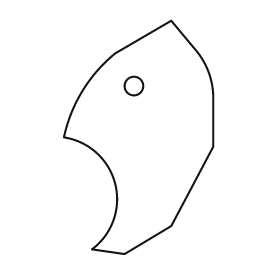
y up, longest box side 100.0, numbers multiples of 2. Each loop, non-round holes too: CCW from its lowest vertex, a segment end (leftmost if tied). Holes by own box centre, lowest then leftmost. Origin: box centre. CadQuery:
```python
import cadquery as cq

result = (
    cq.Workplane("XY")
    .moveTo(-6.0, -50.0)
    .lineTo(14.0, -38.0)
    .lineTo(32.0, -4.0)
    .lineTo(32.0, 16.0)
    .threePointArc((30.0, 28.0), (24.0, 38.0))
    .lineTo(14.0, 50.0)
    .lineTo(-10.0, 36.0)
    .threePointArc((-24.0, 20.0), (-32.0, 0.0))
    .threePointArc((-10.0, -20.0), (-20.0, -48.0))
    .close()
    .moveTo(-2.0, 22.0)
    .circle(4.0)
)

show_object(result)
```